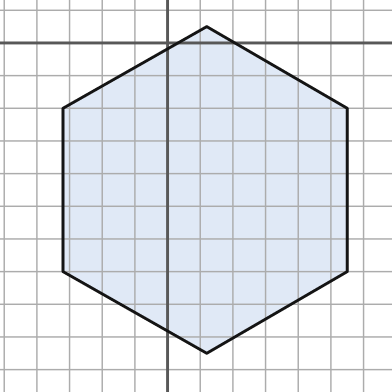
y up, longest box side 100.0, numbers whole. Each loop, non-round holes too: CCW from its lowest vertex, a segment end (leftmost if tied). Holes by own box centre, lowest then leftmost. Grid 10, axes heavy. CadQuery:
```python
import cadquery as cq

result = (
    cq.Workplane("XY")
    .moveTo(12.0, -95.0)
    .lineTo(55.0, -70.0)
    .lineTo(55.0, -20.0)
    .lineTo(12.0, 5.0)
    .lineTo(-32.0, -20.0)
    .lineTo(-32.0, -70.0)
    .close()
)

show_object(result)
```